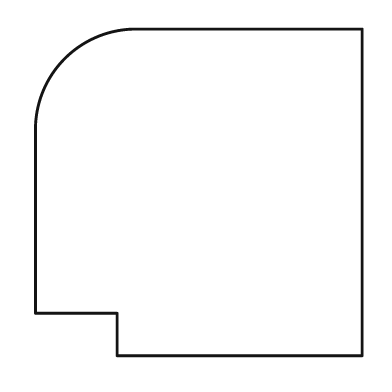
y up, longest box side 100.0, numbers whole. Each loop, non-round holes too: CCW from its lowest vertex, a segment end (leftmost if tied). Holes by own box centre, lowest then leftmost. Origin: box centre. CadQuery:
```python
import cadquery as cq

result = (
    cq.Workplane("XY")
    .moveTo(-25.0, -50.0)
    .lineTo(50.0, -50.0)
    .lineTo(50.0, 50.0)
    .lineTo(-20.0, 50.0)
    .threePointArc((-41.0, 41.0), (-50.0, 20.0))
    .lineTo(-50.0, -37.0)
    .lineTo(-25.0, -37.0)
    .close()
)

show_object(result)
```